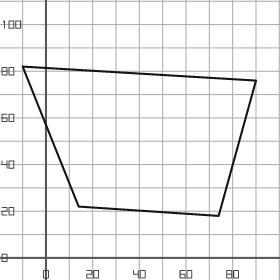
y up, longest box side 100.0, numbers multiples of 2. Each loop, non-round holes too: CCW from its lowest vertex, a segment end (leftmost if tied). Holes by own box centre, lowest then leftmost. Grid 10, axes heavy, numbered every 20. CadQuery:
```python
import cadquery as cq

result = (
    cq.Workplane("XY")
    .moveTo(74.0, 18.0)
    .lineTo(90.0, 76.0)
    .lineTo(-10.0, 82.0)
    .lineTo(14.0, 22.0)
    .close()
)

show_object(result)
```